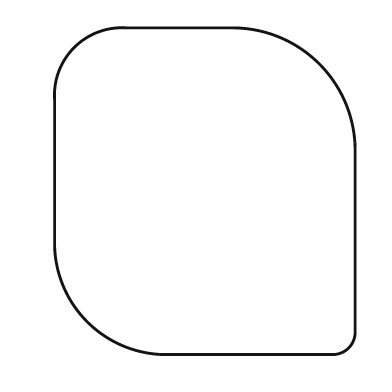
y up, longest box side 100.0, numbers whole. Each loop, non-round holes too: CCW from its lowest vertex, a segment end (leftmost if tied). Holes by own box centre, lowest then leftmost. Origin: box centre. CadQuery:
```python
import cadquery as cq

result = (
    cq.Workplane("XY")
    .moveTo(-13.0, -50.0)
    .lineTo(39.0, -50.0)
    .threePointArc((44.0, -48.0), (46.0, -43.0))
    .lineTo(46.0, 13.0)
    .threePointArc((35.0, 39.0), (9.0, 50.0))
    .lineTo(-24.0, 50.0)
    .threePointArc((-40.0, 44.0), (-46.0, 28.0))
    .lineTo(-46.0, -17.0)
    .threePointArc((-36.0, -40.0), (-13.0, -50.0))
    .close()
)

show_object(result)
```